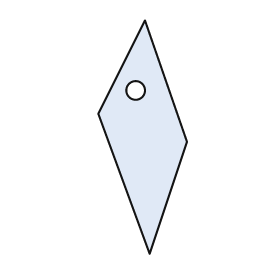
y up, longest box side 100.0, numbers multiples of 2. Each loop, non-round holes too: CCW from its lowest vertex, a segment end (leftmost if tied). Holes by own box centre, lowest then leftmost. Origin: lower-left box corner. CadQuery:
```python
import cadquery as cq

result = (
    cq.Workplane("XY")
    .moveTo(22.0, 0.0)
    .lineTo(38.0, 48.0)
    .lineTo(20.0, 100.0)
    .lineTo(0.0, 60.0)
    .close()
    .moveTo(16.0, 70.0)
    .circle(4.0)
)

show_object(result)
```